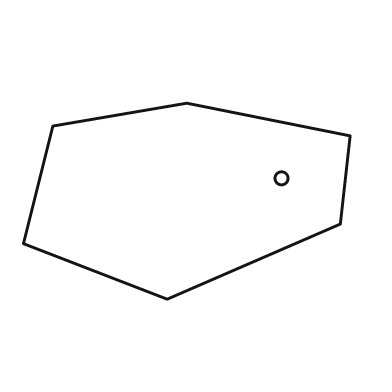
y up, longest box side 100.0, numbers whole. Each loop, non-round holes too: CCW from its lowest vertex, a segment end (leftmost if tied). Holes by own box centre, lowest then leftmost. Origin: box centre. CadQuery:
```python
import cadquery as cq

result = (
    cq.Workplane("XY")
    .moveTo(-6.0, -30.0)
    .lineTo(47.0, -7.0)
    .lineTo(50.0, 20.0)
    .lineTo(0.0, 30.0)
    .lineTo(-41.0, 23.0)
    .lineTo(-50.0, -13.0)
    .close()
    .moveTo(29.0, 7.0)
    .circle(2.0)
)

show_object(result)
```